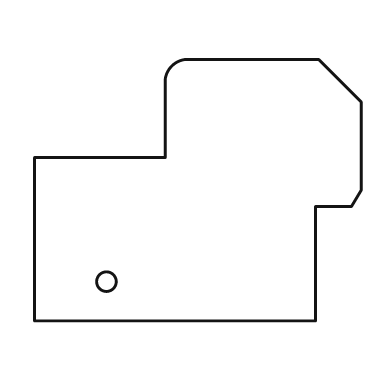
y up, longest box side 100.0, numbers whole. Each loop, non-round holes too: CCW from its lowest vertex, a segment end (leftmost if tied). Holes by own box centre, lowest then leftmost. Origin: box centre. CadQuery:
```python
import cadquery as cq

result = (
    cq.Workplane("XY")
    .moveTo(-50.0, -40.0)
    .lineTo(36.0, -40.0)
    .lineTo(36.0, -5.0)
    .lineTo(47.0, -5.0)
    .lineTo(50.0, 0.0)
    .lineTo(50.0, 27.0)
    .lineTo(37.0, 40.0)
    .lineTo(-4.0, 40.0)
    .threePointArc((-8.0, 38.0), (-10.0, 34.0))
    .lineTo(-10.0, 10.0)
    .lineTo(-50.0, 10.0)
    .close()
    .moveTo(-28.0, -28.0)
    .circle(3.0)
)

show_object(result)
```